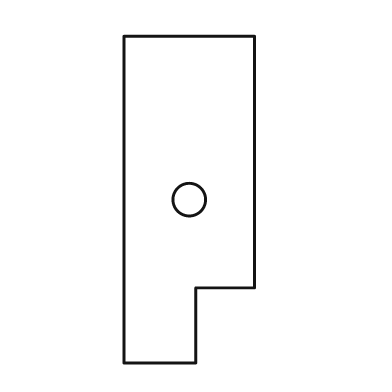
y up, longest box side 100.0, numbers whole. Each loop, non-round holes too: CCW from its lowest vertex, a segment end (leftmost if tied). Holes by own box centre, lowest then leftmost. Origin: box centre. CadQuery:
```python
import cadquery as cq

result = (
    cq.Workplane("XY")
    .moveTo(-20.0, -50.0)
    .lineTo(2.0, -50.0)
    .lineTo(2.0, -27.0)
    .lineTo(20.0, -27.0)
    .lineTo(20.0, 50.0)
    .lineTo(-20.0, 50.0)
    .close()
    .moveTo(0.0, 0.0)
    .circle(5.0)
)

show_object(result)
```